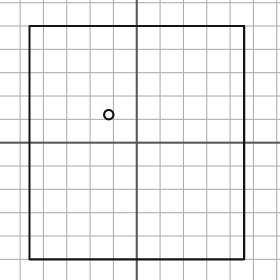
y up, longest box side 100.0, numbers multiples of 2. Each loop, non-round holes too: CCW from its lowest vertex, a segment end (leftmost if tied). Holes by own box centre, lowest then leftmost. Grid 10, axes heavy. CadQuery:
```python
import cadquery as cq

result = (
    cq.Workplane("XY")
    .moveTo(-46.0, -50.0)
    .lineTo(46.0, -50.0)
    .lineTo(46.0, 50.0)
    .lineTo(-46.0, 50.0)
    .close()
    .moveTo(-12.0, 12.0)
    .circle(2.0)
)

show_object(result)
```